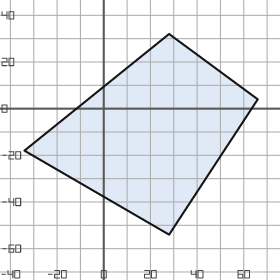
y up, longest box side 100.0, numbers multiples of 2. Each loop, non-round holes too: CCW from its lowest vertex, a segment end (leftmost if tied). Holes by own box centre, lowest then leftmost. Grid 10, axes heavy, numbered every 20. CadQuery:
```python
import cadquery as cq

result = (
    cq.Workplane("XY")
    .moveTo(28.0, -54.0)
    .lineTo(66.0, 4.0)
    .lineTo(28.0, 32.0)
    .lineTo(-34.0, -18.0)
    .close()
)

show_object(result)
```